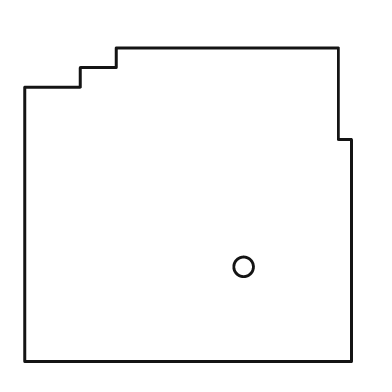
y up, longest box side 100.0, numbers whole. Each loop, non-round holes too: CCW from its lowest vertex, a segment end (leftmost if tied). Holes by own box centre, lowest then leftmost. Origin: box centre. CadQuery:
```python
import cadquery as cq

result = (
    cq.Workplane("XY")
    .moveTo(-50.0, -48.0)
    .lineTo(50.0, -48.0)
    .lineTo(50.0, 20.0)
    .lineTo(46.0, 20.0)
    .lineTo(46.0, 48.0)
    .lineTo(-22.0, 48.0)
    .lineTo(-22.0, 42.0)
    .lineTo(-33.0, 42.0)
    .lineTo(-33.0, 36.0)
    .lineTo(-50.0, 36.0)
    .close()
    .moveTo(17.0, -19.0)
    .circle(3.0)
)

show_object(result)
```